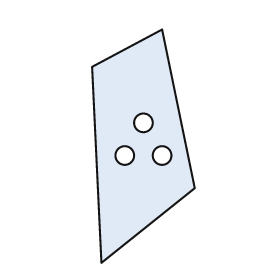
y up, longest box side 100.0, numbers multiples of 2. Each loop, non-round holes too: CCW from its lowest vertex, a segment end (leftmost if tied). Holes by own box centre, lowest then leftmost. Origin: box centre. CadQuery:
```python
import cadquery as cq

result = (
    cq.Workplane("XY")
    .moveTo(-18.0, -50.0)
    .lineTo(22.0, -18.0)
    .lineTo(8.0, 50.0)
    .lineTo(-22.0, 34.0)
    .close()
    .moveTo(-8.0, -4.0)
    .circle(4.0)
    .moveTo(8.0, -4.0)
    .circle(4.0)
    .moveTo(0.0, 10.0)
    .circle(4.0)
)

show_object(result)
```